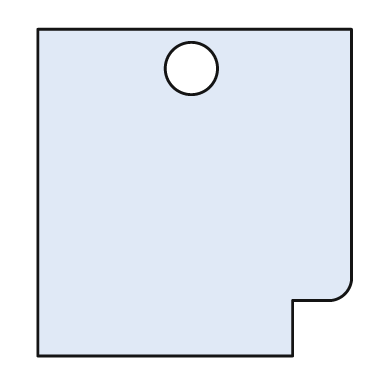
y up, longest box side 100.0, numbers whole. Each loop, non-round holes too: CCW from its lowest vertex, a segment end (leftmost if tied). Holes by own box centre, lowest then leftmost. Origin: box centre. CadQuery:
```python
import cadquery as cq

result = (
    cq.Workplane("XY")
    .moveTo(-48.0, -50.0)
    .lineTo(30.0, -50.0)
    .lineTo(30.0, -33.0)
    .lineTo(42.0, -33.0)
    .threePointArc((46.0, -31.0), (48.0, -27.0))
    .lineTo(48.0, 50.0)
    .lineTo(-48.0, 50.0)
    .close()
    .moveTo(-1.0, 38.0)
    .circle(8.0)
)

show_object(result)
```